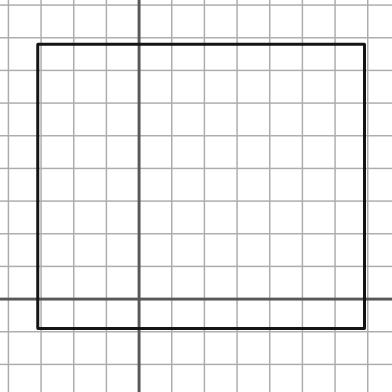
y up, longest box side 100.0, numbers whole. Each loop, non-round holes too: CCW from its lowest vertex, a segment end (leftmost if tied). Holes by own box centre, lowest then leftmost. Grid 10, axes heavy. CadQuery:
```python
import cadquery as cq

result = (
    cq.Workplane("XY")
    .moveTo(-31.0, -9.0)
    .lineTo(69.0, -9.0)
    .lineTo(69.0, 78.0)
    .lineTo(-31.0, 78.0)
    .close()
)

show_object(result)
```